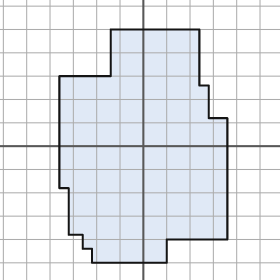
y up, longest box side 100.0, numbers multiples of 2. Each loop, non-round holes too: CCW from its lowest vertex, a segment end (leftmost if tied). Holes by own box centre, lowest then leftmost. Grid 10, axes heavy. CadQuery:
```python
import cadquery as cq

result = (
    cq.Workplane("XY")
    .moveTo(-22.0, -50.0)
    .lineTo(10.0, -50.0)
    .lineTo(10.0, -40.0)
    .lineTo(36.0, -40.0)
    .lineTo(36.0, 12.0)
    .lineTo(28.0, 12.0)
    .lineTo(28.0, 26.0)
    .lineTo(24.0, 26.0)
    .lineTo(24.0, 50.0)
    .lineTo(-14.0, 50.0)
    .lineTo(-14.0, 30.0)
    .lineTo(-36.0, 30.0)
    .lineTo(-36.0, -18.0)
    .lineTo(-32.0, -18.0)
    .lineTo(-32.0, -38.0)
    .lineTo(-26.0, -38.0)
    .lineTo(-26.0, -44.0)
    .lineTo(-22.0, -44.0)
    .close()
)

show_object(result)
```